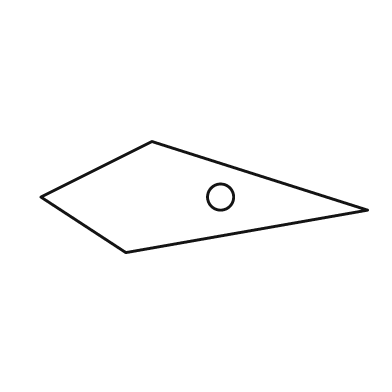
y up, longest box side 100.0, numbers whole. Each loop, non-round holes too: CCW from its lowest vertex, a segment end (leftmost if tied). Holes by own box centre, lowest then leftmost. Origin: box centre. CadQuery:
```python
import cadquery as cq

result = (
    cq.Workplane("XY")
    .moveTo(-24.0, -17.0)
    .lineTo(50.0, -4.0)
    .lineTo(-16.0, 17.0)
    .lineTo(-50.0, 0.0)
    .close()
    .moveTo(5.0, 0.0)
    .circle(4.0)
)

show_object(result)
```